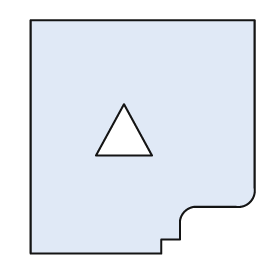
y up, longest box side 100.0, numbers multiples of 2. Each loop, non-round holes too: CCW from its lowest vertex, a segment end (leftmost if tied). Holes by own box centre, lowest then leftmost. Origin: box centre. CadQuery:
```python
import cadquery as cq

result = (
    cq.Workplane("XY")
    .moveTo(-48.0, -50.0)
    .lineTo(8.0, -50.0)
    .lineTo(8.0, -44.0)
    .lineTo(16.0, -44.0)
    .lineTo(16.0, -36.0)
    .threePointArc((18.0, -32.0), (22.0, -30.0))
    .lineTo(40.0, -30.0)
    .threePointArc((46.0, -28.0), (48.0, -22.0))
    .lineTo(48.0, 50.0)
    .lineTo(-48.0, 50.0)
    .close()
    .moveTo(-20.0, -8.0)
    .lineTo(4.0, -8.0)
    .lineTo(-8.0, 14.0)
    .close()
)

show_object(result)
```